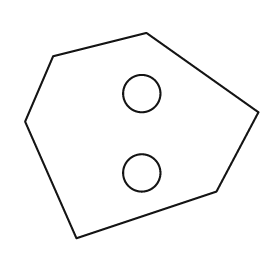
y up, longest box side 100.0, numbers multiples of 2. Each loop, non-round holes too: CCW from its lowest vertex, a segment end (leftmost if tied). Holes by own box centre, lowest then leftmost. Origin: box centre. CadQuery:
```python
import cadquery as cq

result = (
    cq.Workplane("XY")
    .moveTo(-28.0, -44.0)
    .lineTo(32.0, -24.0)
    .lineTo(50.0, 10.0)
    .lineTo(2.0, 44.0)
    .lineTo(-38.0, 34.0)
    .lineTo(-50.0, 6.0)
    .close()
    .moveTo(0.0, -16.0)
    .circle(8.0)
    .moveTo(0.0, 18.0)
    .circle(8.0)
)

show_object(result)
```